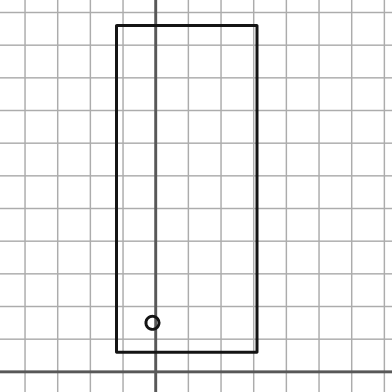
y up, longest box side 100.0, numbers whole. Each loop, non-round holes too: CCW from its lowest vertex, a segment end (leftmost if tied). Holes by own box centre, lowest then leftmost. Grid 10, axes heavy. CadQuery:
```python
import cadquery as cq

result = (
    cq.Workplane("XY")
    .moveTo(-12.0, 6.0)
    .lineTo(31.0, 6.0)
    .lineTo(31.0, 106.0)
    .lineTo(-12.0, 106.0)
    .close()
    .moveTo(-1.0, 15.0)
    .circle(2.0)
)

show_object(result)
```